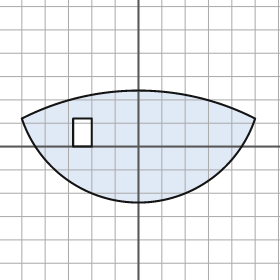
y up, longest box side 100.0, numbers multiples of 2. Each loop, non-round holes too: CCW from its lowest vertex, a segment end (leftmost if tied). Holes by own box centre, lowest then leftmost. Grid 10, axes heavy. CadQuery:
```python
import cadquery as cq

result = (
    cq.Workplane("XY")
    .moveTo(-50.0, 12.0)
    .threePointArc((0.0, -24.0), (50.0, 12.0))
    .threePointArc((0.0, 24.0), (-50.0, 12.0))
    .close()
    .moveTo(-28.0, 0.0)
    .lineTo(-20.0, 0.0)
    .lineTo(-20.0, 12.0)
    .lineTo(-28.0, 12.0)
    .close()
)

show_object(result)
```